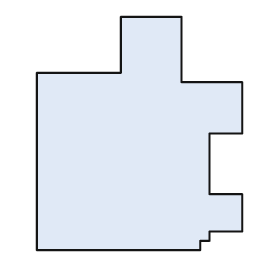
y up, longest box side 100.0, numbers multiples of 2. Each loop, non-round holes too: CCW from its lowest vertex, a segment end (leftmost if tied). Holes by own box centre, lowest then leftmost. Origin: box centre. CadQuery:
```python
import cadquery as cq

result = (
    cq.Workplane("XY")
    .moveTo(-44.0, -50.0)
    .lineTo(26.0, -50.0)
    .lineTo(26.0, -46.0)
    .lineTo(30.0, -46.0)
    .lineTo(30.0, -42.0)
    .lineTo(44.0, -42.0)
    .lineTo(44.0, -26.0)
    .lineTo(30.0, -26.0)
    .lineTo(30.0, 0.0)
    .lineTo(44.0, 0.0)
    .lineTo(44.0, 22.0)
    .lineTo(18.0, 22.0)
    .lineTo(18.0, 50.0)
    .lineTo(-8.0, 50.0)
    .lineTo(-8.0, 26.0)
    .lineTo(-44.0, 26.0)
    .close()
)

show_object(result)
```